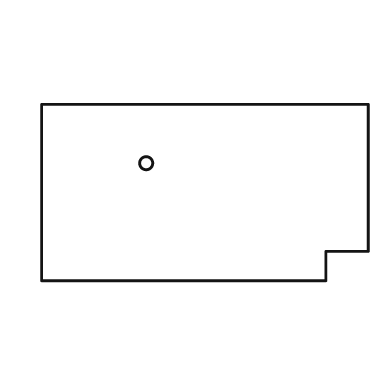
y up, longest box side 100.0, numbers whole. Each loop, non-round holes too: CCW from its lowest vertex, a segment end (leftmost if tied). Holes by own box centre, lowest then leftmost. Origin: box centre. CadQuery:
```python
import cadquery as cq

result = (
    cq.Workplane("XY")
    .moveTo(-50.0, -27.0)
    .lineTo(37.0, -27.0)
    .lineTo(37.0, -18.0)
    .lineTo(50.0, -18.0)
    .lineTo(50.0, 27.0)
    .lineTo(-50.0, 27.0)
    .close()
    .moveTo(-18.0, 9.0)
    .circle(2.0)
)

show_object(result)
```